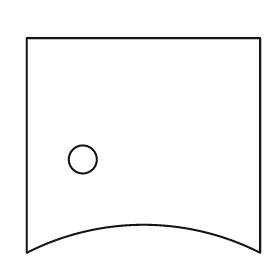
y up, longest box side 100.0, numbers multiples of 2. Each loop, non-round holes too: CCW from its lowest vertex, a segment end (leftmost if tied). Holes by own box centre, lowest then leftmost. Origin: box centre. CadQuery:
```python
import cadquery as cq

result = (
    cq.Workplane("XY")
    .moveTo(-50.0, -46.0)
    .threePointArc((0.0, -34.0), (50.0, -46.0))
    .lineTo(50.0, 46.0)
    .lineTo(-50.0, 46.0)
    .close()
    .moveTo(-26.0, -6.0)
    .circle(6.0)
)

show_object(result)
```